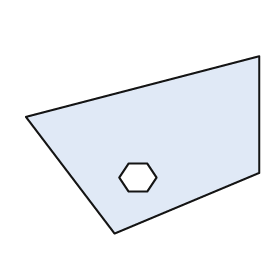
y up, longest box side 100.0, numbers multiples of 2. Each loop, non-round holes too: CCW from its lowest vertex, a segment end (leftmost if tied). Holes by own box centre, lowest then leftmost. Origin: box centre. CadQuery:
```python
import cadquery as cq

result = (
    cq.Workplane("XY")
    .moveTo(-12.0, -38.0)
    .lineTo(50.0, -12.0)
    .lineTo(50.0, 38.0)
    .lineTo(-50.0, 12.0)
    .close()
    .moveTo(-6.0, -20.0)
    .lineTo(2.0, -20.0)
    .lineTo(6.0, -14.0)
    .lineTo(2.0, -8.0)
    .lineTo(-6.0, -8.0)
    .lineTo(-10.0, -14.0)
    .close()
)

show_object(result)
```